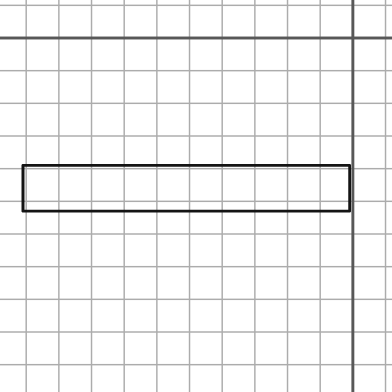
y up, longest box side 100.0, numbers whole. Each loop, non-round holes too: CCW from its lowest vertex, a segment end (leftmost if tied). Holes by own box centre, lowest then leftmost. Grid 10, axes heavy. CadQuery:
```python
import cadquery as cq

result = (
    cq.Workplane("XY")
    .moveTo(-101.0, -53.0)
    .lineTo(-1.0, -53.0)
    .lineTo(-1.0, -39.0)
    .lineTo(-101.0, -39.0)
    .close()
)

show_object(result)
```